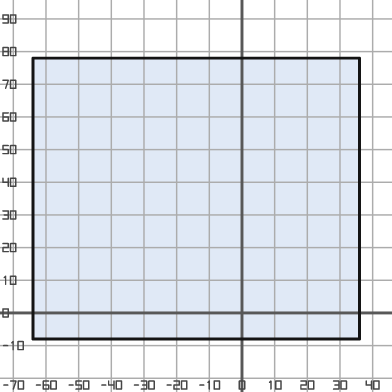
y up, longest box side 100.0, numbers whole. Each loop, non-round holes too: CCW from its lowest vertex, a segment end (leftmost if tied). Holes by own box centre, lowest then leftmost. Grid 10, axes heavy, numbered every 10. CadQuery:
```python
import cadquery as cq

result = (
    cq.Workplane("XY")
    .moveTo(-64.0, -8.0)
    .lineTo(36.0, -8.0)
    .lineTo(36.0, 78.0)
    .lineTo(-64.0, 78.0)
    .close()
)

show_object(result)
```